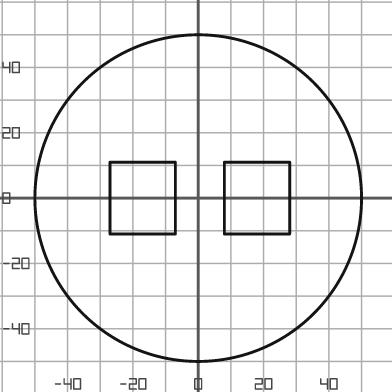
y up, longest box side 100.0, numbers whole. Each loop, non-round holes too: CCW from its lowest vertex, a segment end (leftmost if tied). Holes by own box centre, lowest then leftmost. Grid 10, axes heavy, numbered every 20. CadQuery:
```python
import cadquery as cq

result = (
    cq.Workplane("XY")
    .moveTo(0.0, 0.0)
    .circle(50.0)
    .moveTo(-27.0, -11.0)
    .lineTo(-7.0, -11.0)
    .lineTo(-7.0, 11.0)
    .lineTo(-27.0, 11.0)
    .close()
    .moveTo(8.0, -11.0)
    .lineTo(28.0, -11.0)
    .lineTo(28.0, 11.0)
    .lineTo(8.0, 11.0)
    .close()
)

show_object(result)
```